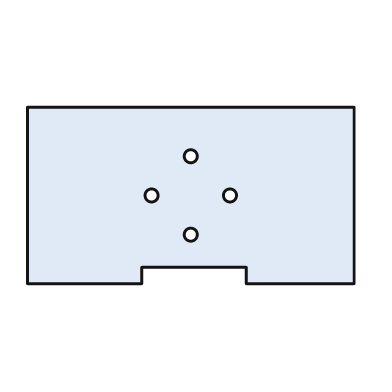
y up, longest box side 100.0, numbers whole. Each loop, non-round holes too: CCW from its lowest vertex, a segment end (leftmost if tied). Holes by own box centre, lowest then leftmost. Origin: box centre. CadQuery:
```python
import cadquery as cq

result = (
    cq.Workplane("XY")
    .moveTo(-50.0, -27.0)
    .lineTo(-15.0, -27.0)
    .lineTo(-15.0, -22.0)
    .lineTo(17.0, -22.0)
    .lineTo(17.0, -27.0)
    .lineTo(50.0, -27.0)
    .lineTo(50.0, 27.0)
    .lineTo(-50.0, 27.0)
    .close()
    .moveTo(0.0, -12.0)
    .circle(2.0)
    .moveTo(-12.0, 0.0)
    .circle(2.0)
    .moveTo(12.0, 0.0)
    .circle(2.0)
    .moveTo(0.0, 12.0)
    .circle(2.0)
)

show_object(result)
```